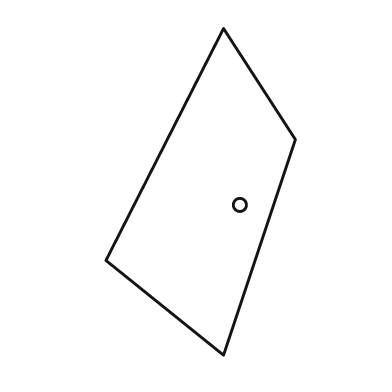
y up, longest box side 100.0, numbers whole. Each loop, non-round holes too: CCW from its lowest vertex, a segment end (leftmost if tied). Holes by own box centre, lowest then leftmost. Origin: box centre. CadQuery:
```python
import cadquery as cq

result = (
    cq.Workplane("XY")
    .moveTo(7.0, -50.0)
    .lineTo(29.0, 16.0)
    .lineTo(7.0, 50.0)
    .lineTo(-29.0, -21.0)
    .close()
    .moveTo(12.0, -4.0)
    .circle(2.0)
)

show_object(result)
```